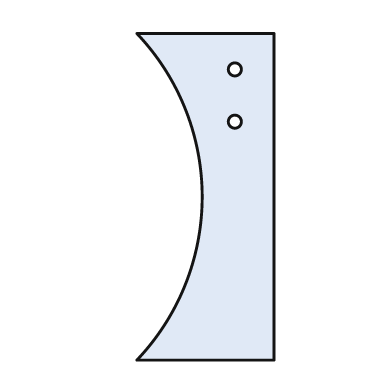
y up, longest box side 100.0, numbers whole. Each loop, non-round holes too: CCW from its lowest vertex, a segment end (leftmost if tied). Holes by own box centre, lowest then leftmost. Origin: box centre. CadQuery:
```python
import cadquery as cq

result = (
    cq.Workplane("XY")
    .moveTo(-21.0, -50.0)
    .lineTo(21.0, -50.0)
    .lineTo(21.0, 50.0)
    .lineTo(-21.0, 50.0)
    .threePointArc((-1.0, 0.0), (-21.0, -50.0))
    .close()
    .moveTo(9.0, 23.0)
    .circle(2.0)
    .moveTo(9.0, 39.0)
    .circle(2.0)
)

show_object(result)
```